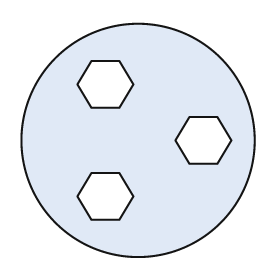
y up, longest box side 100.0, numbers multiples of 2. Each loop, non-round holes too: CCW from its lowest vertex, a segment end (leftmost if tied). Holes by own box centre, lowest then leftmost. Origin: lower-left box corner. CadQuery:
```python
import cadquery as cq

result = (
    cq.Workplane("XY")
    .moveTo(50.0, 50.0)
    .circle(50.0)
    .moveTo(30.0, 16.0)
    .lineTo(42.0, 16.0)
    .lineTo(48.0, 26.0)
    .lineTo(42.0, 36.0)
    .lineTo(30.0, 36.0)
    .lineTo(24.0, 26.0)
    .close()
    .moveTo(72.0, 40.0)
    .lineTo(84.0, 40.0)
    .lineTo(90.0, 50.0)
    .lineTo(84.0, 60.0)
    .lineTo(72.0, 60.0)
    .lineTo(66.0, 50.0)
    .close()
    .moveTo(30.0, 64.0)
    .lineTo(42.0, 64.0)
    .lineTo(48.0, 74.0)
    .lineTo(42.0, 84.0)
    .lineTo(30.0, 84.0)
    .lineTo(24.0, 74.0)
    .close()
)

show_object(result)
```